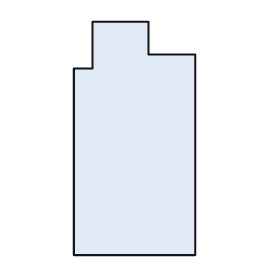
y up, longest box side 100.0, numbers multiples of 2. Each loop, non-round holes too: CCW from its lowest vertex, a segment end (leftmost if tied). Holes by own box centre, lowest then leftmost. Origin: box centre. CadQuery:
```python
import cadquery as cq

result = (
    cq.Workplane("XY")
    .moveTo(-26.0, -50.0)
    .lineTo(26.0, -50.0)
    .lineTo(26.0, 36.0)
    .lineTo(6.0, 36.0)
    .lineTo(6.0, 50.0)
    .lineTo(-18.0, 50.0)
    .lineTo(-18.0, 30.0)
    .lineTo(-26.0, 30.0)
    .close()
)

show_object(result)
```